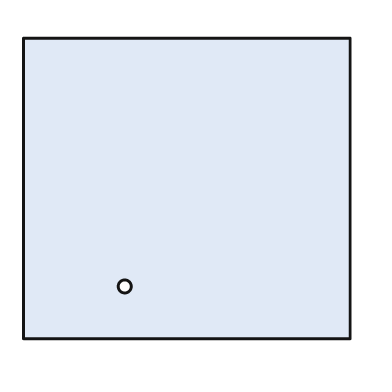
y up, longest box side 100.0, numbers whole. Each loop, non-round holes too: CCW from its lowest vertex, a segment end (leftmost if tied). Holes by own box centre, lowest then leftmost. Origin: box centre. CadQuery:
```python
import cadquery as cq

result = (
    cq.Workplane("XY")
    .moveTo(-50.0, -46.0)
    .lineTo(50.0, -46.0)
    .lineTo(50.0, 46.0)
    .lineTo(-50.0, 46.0)
    .close()
    .moveTo(-19.0, -30.0)
    .circle(2.0)
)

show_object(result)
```